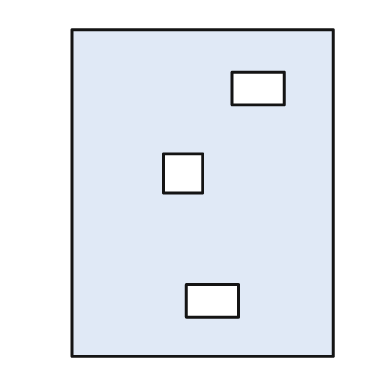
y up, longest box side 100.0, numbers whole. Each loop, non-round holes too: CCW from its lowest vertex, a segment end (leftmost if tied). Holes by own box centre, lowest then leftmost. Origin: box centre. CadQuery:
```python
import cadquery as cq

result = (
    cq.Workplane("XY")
    .moveTo(-40.0, -50.0)
    .lineTo(40.0, -50.0)
    .lineTo(40.0, 50.0)
    .lineTo(-40.0, 50.0)
    .close()
    .moveTo(-5.0, -38.0)
    .lineTo(11.0, -38.0)
    .lineTo(11.0, -28.0)
    .lineTo(-5.0, -28.0)
    .close()
    .moveTo(-12.0, 0.0)
    .lineTo(0.0, 0.0)
    .lineTo(0.0, 12.0)
    .lineTo(-12.0, 12.0)
    .close()
    .moveTo(9.0, 27.0)
    .lineTo(25.0, 27.0)
    .lineTo(25.0, 37.0)
    .lineTo(9.0, 37.0)
    .close()
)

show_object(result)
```